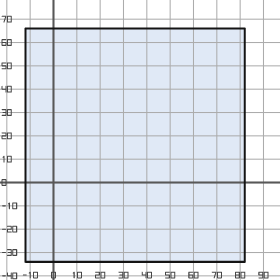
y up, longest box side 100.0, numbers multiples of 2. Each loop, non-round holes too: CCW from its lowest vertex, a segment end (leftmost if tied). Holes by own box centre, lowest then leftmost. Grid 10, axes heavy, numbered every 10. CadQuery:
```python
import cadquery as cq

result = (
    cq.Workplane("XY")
    .moveTo(-12.0, -34.0)
    .lineTo(82.0, -34.0)
    .lineTo(82.0, 66.0)
    .lineTo(-12.0, 66.0)
    .close()
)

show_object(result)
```